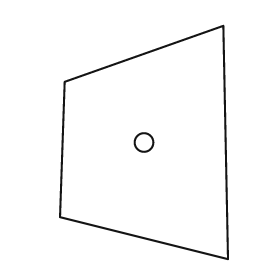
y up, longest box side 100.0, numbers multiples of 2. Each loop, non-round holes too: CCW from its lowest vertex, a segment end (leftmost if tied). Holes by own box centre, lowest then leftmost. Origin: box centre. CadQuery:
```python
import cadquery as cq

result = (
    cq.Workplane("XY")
    .moveTo(36.0, -50.0)
    .lineTo(34.0, 50.0)
    .lineTo(-34.0, 26.0)
    .lineTo(-36.0, -32.0)
    .close()
    .moveTo(0.0, 0.0)
    .circle(4.0)
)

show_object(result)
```